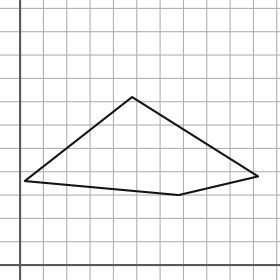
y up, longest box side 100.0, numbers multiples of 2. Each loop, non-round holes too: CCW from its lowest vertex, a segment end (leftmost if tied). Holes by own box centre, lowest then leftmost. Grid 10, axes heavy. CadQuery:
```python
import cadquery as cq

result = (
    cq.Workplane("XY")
    .moveTo(68.0, 30.0)
    .lineTo(102.0, 38.0)
    .lineTo(48.0, 72.0)
    .lineTo(2.0, 36.0)
    .close()
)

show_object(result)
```